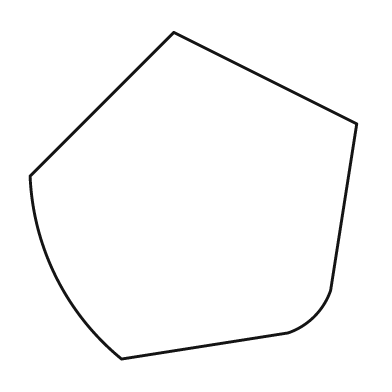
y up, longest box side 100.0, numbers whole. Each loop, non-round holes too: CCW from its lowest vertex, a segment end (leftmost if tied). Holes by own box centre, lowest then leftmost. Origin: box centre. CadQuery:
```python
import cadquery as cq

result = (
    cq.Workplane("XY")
    .moveTo(-22.0, -50.0)
    .lineTo(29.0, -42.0)
    .threePointArc((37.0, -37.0), (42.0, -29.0))
    .lineTo(50.0, 22.0)
    .lineTo(-6.0, 50.0)
    .lineTo(-50.0, 6.0)
    .threePointArc((-42.0, -25.0), (-22.0, -50.0))
    .close()
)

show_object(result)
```